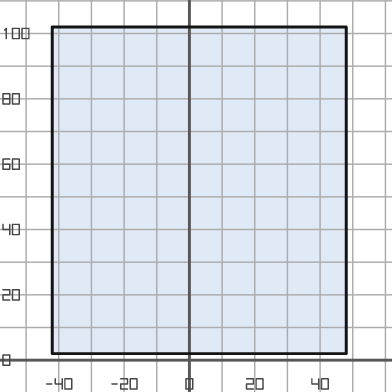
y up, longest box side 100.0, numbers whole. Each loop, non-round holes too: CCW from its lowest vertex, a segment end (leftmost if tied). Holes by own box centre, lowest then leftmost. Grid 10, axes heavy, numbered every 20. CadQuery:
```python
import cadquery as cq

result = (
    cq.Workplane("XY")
    .moveTo(-42.0, 2.0)
    .lineTo(48.0, 2.0)
    .lineTo(48.0, 102.0)
    .lineTo(-42.0, 102.0)
    .close()
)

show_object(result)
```